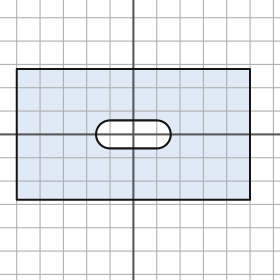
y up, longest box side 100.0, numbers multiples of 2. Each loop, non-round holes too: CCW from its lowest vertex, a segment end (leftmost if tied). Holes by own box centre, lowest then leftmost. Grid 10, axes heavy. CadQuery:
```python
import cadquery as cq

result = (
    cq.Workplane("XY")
    .moveTo(-50.0, -28.0)
    .lineTo(50.0, -28.0)
    .lineTo(50.0, 28.0)
    .lineTo(-50.0, 28.0)
    .close()
    .moveTo(-10.0, -6.0)
    .lineTo(10.0, -6.0)
    .threePointArc((16.0, 0.0), (10.0, 6.0))
    .lineTo(-10.0, 6.0)
    .threePointArc((-16.0, 0.0), (-10.0, -6.0))
    .close()
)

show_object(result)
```